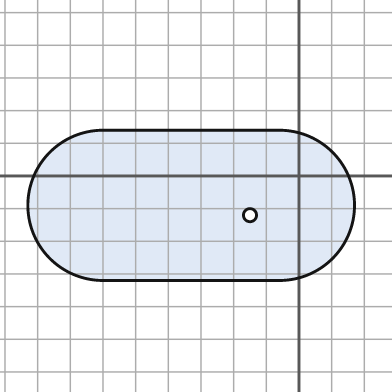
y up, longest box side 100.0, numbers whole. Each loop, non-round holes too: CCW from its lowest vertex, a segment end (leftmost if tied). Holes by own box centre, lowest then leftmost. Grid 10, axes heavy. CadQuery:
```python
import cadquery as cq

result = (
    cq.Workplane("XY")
    .moveTo(-60.0, -32.0)
    .lineTo(-6.0, -32.0)
    .threePointArc((17.0, -9.0), (-6.0, 14.0))
    .lineTo(-60.0, 14.0)
    .threePointArc((-83.0, -9.0), (-60.0, -32.0))
    .close()
    .moveTo(-15.0, -12.0)
    .circle(2.0)
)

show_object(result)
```